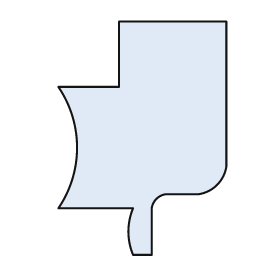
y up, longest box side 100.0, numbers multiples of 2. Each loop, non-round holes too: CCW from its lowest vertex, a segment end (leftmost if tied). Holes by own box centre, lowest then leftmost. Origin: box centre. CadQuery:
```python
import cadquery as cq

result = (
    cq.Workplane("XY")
    .moveTo(-4.0, -50.0)
    .lineTo(4.0, -50.0)
    .lineTo(4.0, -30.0)
    .threePointArc((6.0, -26.0), (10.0, -24.0))
    .lineTo(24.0, -24.0)
    .threePointArc((32.0, -20.0), (36.0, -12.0))
    .lineTo(36.0, 50.0)
    .lineTo(-10.0, 50.0)
    .lineTo(-10.0, 22.0)
    .lineTo(-36.0, 22.0)
    .threePointArc((-28.0, -4.0), (-36.0, -30.0))
    .lineTo(-4.0, -30.0)
    .threePointArc((-6.0, -40.0), (-4.0, -50.0))
    .close()
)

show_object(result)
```